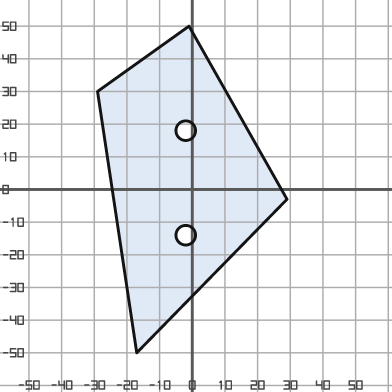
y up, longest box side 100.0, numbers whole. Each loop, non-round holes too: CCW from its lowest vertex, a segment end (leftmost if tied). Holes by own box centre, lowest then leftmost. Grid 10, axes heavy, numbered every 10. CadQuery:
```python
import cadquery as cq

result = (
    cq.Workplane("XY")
    .moveTo(-17.0, -50.0)
    .lineTo(29.0, -3.0)
    .lineTo(-1.0, 50.0)
    .lineTo(-29.0, 30.0)
    .close()
    .moveTo(-2.0, -14.0)
    .circle(3.0)
    .moveTo(-2.0, 18.0)
    .circle(3.0)
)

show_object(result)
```